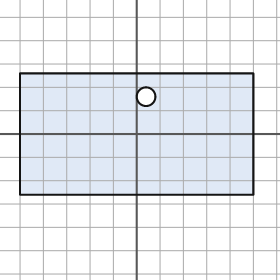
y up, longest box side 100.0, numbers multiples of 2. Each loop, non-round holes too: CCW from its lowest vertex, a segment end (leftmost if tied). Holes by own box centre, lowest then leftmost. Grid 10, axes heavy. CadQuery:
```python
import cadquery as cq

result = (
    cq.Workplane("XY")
    .moveTo(-50.0, -26.0)
    .lineTo(50.0, -26.0)
    .lineTo(50.0, 26.0)
    .lineTo(-50.0, 26.0)
    .close()
    .moveTo(4.0, 16.0)
    .circle(4.0)
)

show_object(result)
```